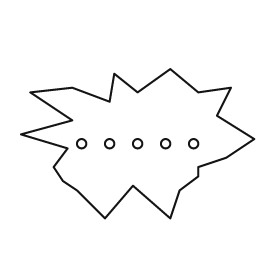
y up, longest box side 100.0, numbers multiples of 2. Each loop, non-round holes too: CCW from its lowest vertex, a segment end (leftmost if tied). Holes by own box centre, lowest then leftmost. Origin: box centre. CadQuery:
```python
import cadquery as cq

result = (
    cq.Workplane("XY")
    .moveTo(-14.0, -32.0)
    .lineTo(-2.0, -18.0)
    .lineTo(14.0, -32.0)
    .lineTo(18.0, -20.0)
    .lineTo(26.0, -14.0)
    .lineTo(26.0, -10.0)
    .lineTo(38.0, -6.0)
    .lineTo(50.0, 2.0)
    .lineTo(34.0, 12.0)
    .lineTo(40.0, 24.0)
    .lineTo(26.0, 22.0)
    .lineTo(14.0, 32.0)
    .lineTo(0.0, 22.0)
    .lineTo(-10.0, 30.0)
    .lineTo(-12.0, 18.0)
    .lineTo(-28.0, 24.0)
    .lineTo(-46.0, 22.0)
    .lineTo(-28.0, 10.0)
    .lineTo(-50.0, 4.0)
    .lineTo(-30.0, -2.0)
    .lineTo(-36.0, -10.0)
    .lineTo(-32.0, -16.0)
    .lineTo(-26.0, -20.0)
    .close()
    .moveTo(-24.0, 0.0)
    .circle(2.0)
    .moveTo(-12.0, 0.0)
    .circle(2.0)
    .moveTo(0.0, 0.0)
    .circle(2.0)
    .moveTo(12.0, 0.0)
    .circle(2.0)
    .moveTo(24.0, 0.0)
    .circle(2.0)
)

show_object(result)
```